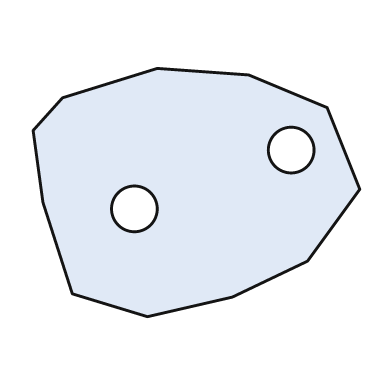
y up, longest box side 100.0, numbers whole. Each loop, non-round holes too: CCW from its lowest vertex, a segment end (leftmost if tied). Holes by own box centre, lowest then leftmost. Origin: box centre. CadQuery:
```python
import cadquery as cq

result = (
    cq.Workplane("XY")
    .moveTo(-15.0, -38.0)
    .lineTo(11.0, -32.0)
    .lineTo(34.0, -21.0)
    .lineTo(50.0, 1.0)
    .lineTo(40.0, 26.0)
    .lineTo(16.0, 36.0)
    .lineTo(-12.0, 38.0)
    .lineTo(-41.0, 29.0)
    .lineTo(-50.0, 19.0)
    .lineTo(-47.0, -3.0)
    .lineTo(-38.0, -31.0)
    .close()
    .moveTo(-19.0, -5.0)
    .circle(7.0)
    .moveTo(29.0, 13.0)
    .circle(7.0)
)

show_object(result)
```